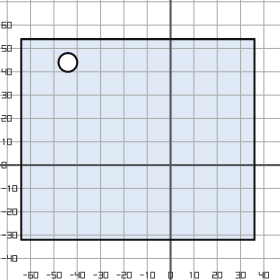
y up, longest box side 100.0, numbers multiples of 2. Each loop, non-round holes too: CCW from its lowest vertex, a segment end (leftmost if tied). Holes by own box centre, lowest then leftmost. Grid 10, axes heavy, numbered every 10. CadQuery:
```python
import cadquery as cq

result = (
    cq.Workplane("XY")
    .moveTo(-64.0, -32.0)
    .lineTo(36.0, -32.0)
    .lineTo(36.0, 54.0)
    .lineTo(-64.0, 54.0)
    .close()
    .moveTo(-44.0, 44.0)
    .circle(4.0)
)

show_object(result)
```